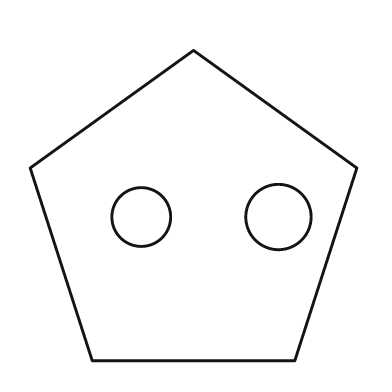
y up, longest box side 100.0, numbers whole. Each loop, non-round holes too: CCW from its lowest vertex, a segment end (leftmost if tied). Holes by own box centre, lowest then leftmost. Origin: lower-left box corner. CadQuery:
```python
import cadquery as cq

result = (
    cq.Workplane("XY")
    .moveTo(19.0, 0.0)
    .lineTo(81.0, 0.0)
    .lineTo(100.0, 59.0)
    .lineTo(50.0, 95.0)
    .lineTo(0.0, 59.0)
    .close()
    .moveTo(34.0, 44.0)
    .circle(9.0)
    .moveTo(76.0, 44.0)
    .circle(10.0)
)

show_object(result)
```